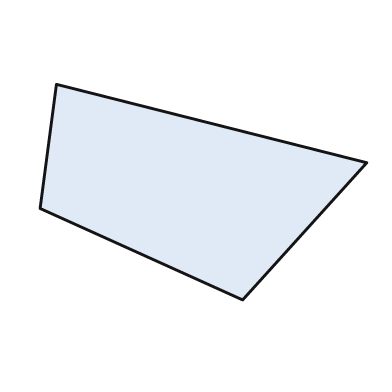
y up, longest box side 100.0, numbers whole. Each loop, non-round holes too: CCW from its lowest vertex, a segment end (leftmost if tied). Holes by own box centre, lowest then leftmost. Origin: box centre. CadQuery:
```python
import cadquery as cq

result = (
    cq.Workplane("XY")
    .moveTo(12.0, -33.0)
    .lineTo(50.0, 9.0)
    .lineTo(-45.0, 33.0)
    .lineTo(-50.0, -5.0)
    .close()
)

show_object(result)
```